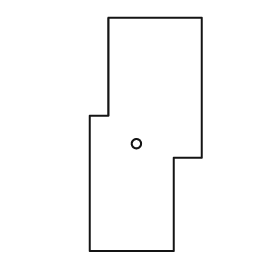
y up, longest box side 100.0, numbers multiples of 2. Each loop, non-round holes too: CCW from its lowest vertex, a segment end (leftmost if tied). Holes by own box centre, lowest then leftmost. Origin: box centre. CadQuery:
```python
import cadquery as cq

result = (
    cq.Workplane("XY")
    .moveTo(-24.0, -50.0)
    .lineTo(12.0, -50.0)
    .lineTo(12.0, -10.0)
    .lineTo(24.0, -10.0)
    .lineTo(24.0, 50.0)
    .lineTo(-16.0, 50.0)
    .lineTo(-16.0, 8.0)
    .lineTo(-24.0, 8.0)
    .close()
    .moveTo(-4.0, -4.0)
    .circle(2.0)
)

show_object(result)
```